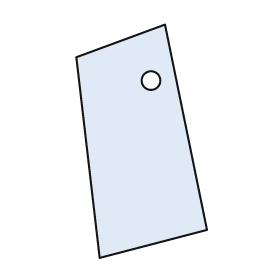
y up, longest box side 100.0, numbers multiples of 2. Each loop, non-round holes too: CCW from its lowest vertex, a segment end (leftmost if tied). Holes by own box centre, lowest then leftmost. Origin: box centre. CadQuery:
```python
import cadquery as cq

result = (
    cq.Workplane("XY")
    .moveTo(-18.0, -50.0)
    .lineTo(28.0, -38.0)
    .lineTo(10.0, 50.0)
    .lineTo(-28.0, 36.0)
    .close()
    .moveTo(4.0, 26.0)
    .circle(4.0)
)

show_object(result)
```